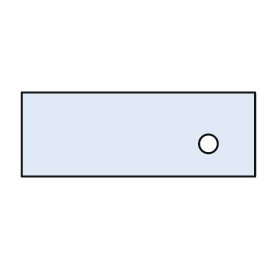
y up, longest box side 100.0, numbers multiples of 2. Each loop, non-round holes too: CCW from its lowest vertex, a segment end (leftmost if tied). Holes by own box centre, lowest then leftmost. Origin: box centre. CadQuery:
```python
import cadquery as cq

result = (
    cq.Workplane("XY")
    .moveTo(-50.0, -18.0)
    .lineTo(50.0, -18.0)
    .lineTo(50.0, 18.0)
    .lineTo(-50.0, 18.0)
    .close()
    .moveTo(30.0, -4.0)
    .circle(4.0)
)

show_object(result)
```